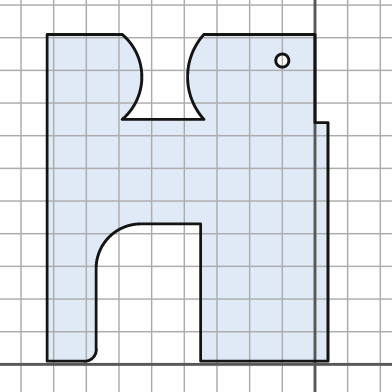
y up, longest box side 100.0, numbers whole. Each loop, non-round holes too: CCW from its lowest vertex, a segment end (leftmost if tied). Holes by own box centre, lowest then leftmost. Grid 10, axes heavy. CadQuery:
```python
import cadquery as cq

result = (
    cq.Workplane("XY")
    .moveTo(-82.0, 1.0)
    .lineTo(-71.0, 1.0)
    .threePointArc((-68.0, 2.0), (-67.0, 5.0))
    .lineTo(-67.0, 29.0)
    .threePointArc((-63.0, 39.0), (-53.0, 43.0))
    .lineTo(-35.0, 43.0)
    .lineTo(-35.0, 1.0)
    .lineTo(4.0, 1.0)
    .lineTo(4.0, 74.0)
    .lineTo(0.0, 74.0)
    .lineTo(0.0, 101.0)
    .lineTo(-34.0, 101.0)
    .threePointArc((-39.0, 88.0), (-34.0, 75.0))
    .lineTo(-59.0, 75.0)
    .threePointArc((-53.0, 88.0), (-59.0, 101.0))
    .lineTo(-82.0, 101.0)
    .close()
    .moveTo(-10.0, 93.0)
    .circle(2.0)
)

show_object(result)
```